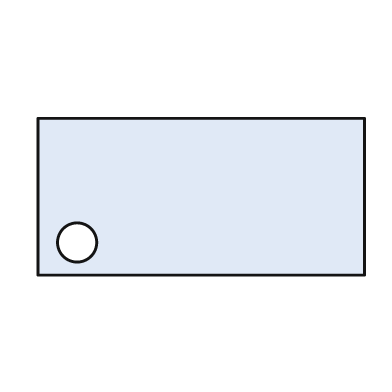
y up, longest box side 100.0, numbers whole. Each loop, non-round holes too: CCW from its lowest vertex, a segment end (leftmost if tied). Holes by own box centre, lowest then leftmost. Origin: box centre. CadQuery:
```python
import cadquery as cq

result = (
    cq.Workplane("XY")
    .moveTo(-50.0, -24.0)
    .lineTo(50.0, -24.0)
    .lineTo(50.0, 24.0)
    .lineTo(-50.0, 24.0)
    .close()
    .moveTo(-38.0, -14.0)
    .circle(6.0)
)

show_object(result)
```